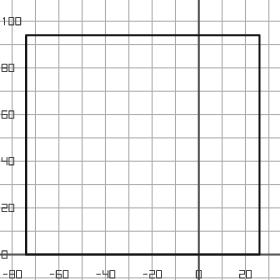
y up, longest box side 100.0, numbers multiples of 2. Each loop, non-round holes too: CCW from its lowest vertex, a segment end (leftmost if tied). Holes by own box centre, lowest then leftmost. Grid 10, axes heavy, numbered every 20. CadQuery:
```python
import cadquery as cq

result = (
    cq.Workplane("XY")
    .moveTo(-74.0, 0.0)
    .lineTo(26.0, 0.0)
    .lineTo(26.0, 94.0)
    .lineTo(-74.0, 94.0)
    .close()
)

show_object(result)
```